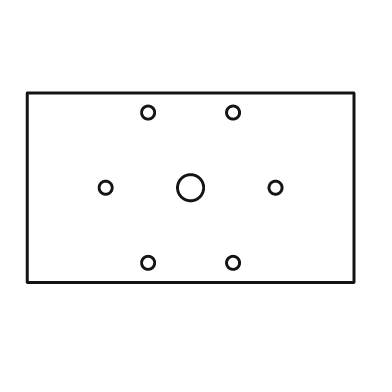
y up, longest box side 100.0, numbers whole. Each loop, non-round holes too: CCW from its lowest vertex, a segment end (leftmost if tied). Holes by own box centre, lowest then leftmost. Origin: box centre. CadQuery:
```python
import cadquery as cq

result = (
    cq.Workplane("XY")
    .moveTo(-50.0, -29.0)
    .lineTo(50.0, -29.0)
    .lineTo(50.0, 29.0)
    .lineTo(-50.0, 29.0)
    .close()
    .moveTo(-13.0, -23.0)
    .circle(2.0)
    .moveTo(13.0, -23.0)
    .circle(2.0)
    .moveTo(-26.0, 0.0)
    .circle(2.0)
    .moveTo(0.0, 0.0)
    .circle(4.0)
    .moveTo(26.0, 0.0)
    .circle(2.0)
    .moveTo(-13.0, 23.0)
    .circle(2.0)
    .moveTo(13.0, 23.0)
    .circle(2.0)
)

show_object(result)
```